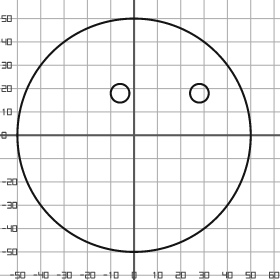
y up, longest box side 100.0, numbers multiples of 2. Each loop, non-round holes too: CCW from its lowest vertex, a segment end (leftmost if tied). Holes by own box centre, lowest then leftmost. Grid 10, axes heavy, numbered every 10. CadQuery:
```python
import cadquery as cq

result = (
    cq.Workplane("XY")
    .moveTo(0.0, 0.0)
    .circle(50.0)
    .moveTo(-6.0, 18.0)
    .circle(4.0)
    .moveTo(28.0, 18.0)
    .circle(4.0)
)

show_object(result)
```